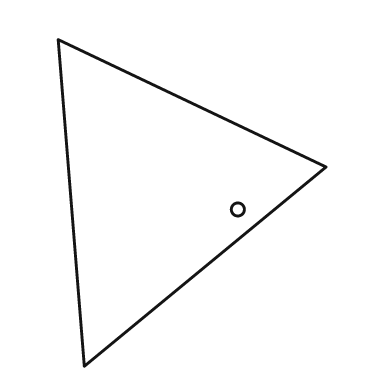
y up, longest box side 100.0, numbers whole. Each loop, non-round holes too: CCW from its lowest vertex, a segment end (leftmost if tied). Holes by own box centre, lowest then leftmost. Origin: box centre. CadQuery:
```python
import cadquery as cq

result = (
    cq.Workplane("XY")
    .moveTo(-33.0, -50.0)
    .lineTo(41.0, 11.0)
    .lineTo(-41.0, 50.0)
    .close()
    .moveTo(14.0, -2.0)
    .circle(2.0)
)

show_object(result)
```